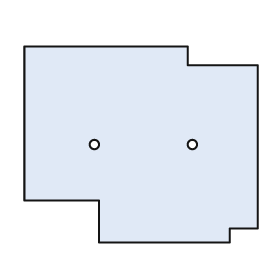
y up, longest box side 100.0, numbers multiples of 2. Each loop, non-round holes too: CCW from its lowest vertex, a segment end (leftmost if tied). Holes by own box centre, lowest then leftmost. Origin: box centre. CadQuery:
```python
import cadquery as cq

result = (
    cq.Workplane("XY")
    .moveTo(-18.0, -42.0)
    .lineTo(38.0, -42.0)
    .lineTo(38.0, -36.0)
    .lineTo(50.0, -36.0)
    .lineTo(50.0, 34.0)
    .lineTo(20.0, 34.0)
    .lineTo(20.0, 42.0)
    .lineTo(-50.0, 42.0)
    .lineTo(-50.0, -24.0)
    .lineTo(-18.0, -24.0)
    .close()
    .moveTo(-20.0, 0.0)
    .circle(2.0)
    .moveTo(22.0, 0.0)
    .circle(2.0)
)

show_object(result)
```